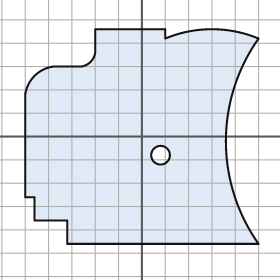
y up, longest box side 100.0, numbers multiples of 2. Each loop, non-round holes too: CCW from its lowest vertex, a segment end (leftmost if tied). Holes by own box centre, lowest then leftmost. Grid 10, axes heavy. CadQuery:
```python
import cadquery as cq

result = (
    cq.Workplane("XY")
    .moveTo(-32.0, -46.0)
    .lineTo(50.0, -46.0)
    .threePointArc((36.0, -2.0), (50.0, 42.0))
    .threePointArc((30.0, 46.0), (10.0, 42.0))
    .lineTo(10.0, 46.0)
    .lineTo(-20.0, 46.0)
    .lineTo(-20.0, 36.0)
    .threePointArc((-22.0, 32.0), (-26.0, 30.0))
    .lineTo(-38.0, 30.0)
    .threePointArc((-46.0, 26.0), (-50.0, 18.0))
    .lineTo(-50.0, -26.0)
    .lineTo(-46.0, -26.0)
    .lineTo(-46.0, -36.0)
    .lineTo(-32.0, -36.0)
    .close()
    .moveTo(8.0, -8.0)
    .circle(4.0)
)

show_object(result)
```